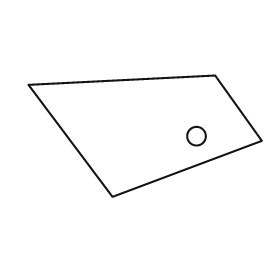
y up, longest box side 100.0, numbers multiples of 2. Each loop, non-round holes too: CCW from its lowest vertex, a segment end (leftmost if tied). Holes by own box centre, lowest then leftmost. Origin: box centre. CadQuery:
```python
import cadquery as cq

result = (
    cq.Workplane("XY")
    .moveTo(-14.0, -26.0)
    .lineTo(50.0, -2.0)
    .lineTo(30.0, 26.0)
    .lineTo(-50.0, 22.0)
    .close()
    .moveTo(22.0, 0.0)
    .circle(4.0)
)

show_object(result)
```